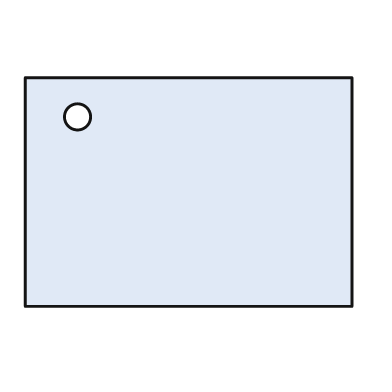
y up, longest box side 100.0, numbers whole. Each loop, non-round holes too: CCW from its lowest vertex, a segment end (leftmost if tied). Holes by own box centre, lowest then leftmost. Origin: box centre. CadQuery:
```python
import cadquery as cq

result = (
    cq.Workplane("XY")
    .moveTo(-50.0, -35.0)
    .lineTo(50.0, -35.0)
    .lineTo(50.0, 35.0)
    .lineTo(-50.0, 35.0)
    .close()
    .moveTo(-34.0, 23.0)
    .circle(4.0)
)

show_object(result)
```